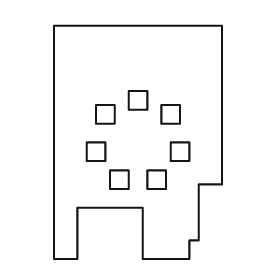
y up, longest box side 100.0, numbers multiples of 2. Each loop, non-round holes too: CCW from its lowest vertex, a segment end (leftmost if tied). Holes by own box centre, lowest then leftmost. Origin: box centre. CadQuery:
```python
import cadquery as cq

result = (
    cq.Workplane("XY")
    .moveTo(-36.0, -50.0)
    .lineTo(-26.0, -50.0)
    .lineTo(-26.0, -28.0)
    .lineTo(2.0, -28.0)
    .lineTo(2.0, -50.0)
    .lineTo(22.0, -50.0)
    .lineTo(22.0, -42.0)
    .lineTo(26.0, -42.0)
    .lineTo(26.0, -18.0)
    .lineTo(36.0, -18.0)
    .lineTo(36.0, 50.0)
    .lineTo(-36.0, 50.0)
    .close()
    .moveTo(-12.0, -20.0)
    .lineTo(-4.0, -20.0)
    .lineTo(-4.0, -12.0)
    .lineTo(-12.0, -12.0)
    .close()
    .moveTo(4.0, -20.0)
    .lineTo(12.0, -20.0)
    .lineTo(12.0, -12.0)
    .lineTo(4.0, -12.0)
    .close()
    .moveTo(-22.0, -8.0)
    .lineTo(-14.0, -8.0)
    .lineTo(-14.0, 0.0)
    .lineTo(-22.0, 0.0)
    .close()
    .moveTo(14.0, -8.0)
    .lineTo(22.0, -8.0)
    .lineTo(22.0, 0.0)
    .lineTo(14.0, 0.0)
    .close()
    .moveTo(-18.0, 8.0)
    .lineTo(-10.0, 8.0)
    .lineTo(-10.0, 16.0)
    .lineTo(-18.0, 16.0)
    .close()
    .moveTo(10.0, 8.0)
    .lineTo(18.0, 8.0)
    .lineTo(18.0, 16.0)
    .lineTo(10.0, 16.0)
    .close()
    .moveTo(-4.0, 14.0)
    .lineTo(4.0, 14.0)
    .lineTo(4.0, 22.0)
    .lineTo(-4.0, 22.0)
    .close()
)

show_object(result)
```